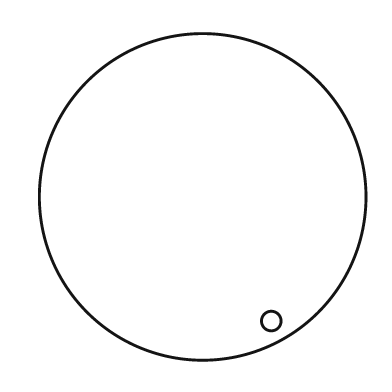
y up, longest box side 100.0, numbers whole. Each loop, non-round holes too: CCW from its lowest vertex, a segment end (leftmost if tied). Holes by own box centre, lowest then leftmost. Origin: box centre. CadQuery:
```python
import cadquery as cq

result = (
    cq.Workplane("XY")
    .moveTo(0.0, 0.0)
    .circle(50.0)
    .moveTo(21.0, -38.0)
    .circle(3.0)
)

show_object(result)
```